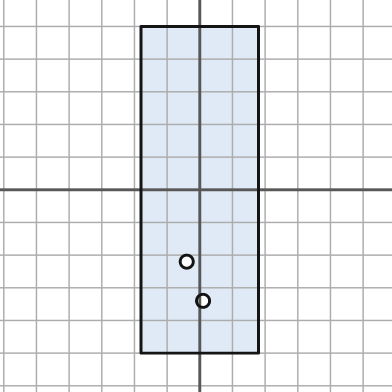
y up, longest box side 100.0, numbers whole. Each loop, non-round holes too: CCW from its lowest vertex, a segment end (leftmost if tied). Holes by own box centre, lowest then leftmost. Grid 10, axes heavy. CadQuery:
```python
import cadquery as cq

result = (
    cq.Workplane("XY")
    .moveTo(-18.0, -50.0)
    .lineTo(18.0, -50.0)
    .lineTo(18.0, 50.0)
    .lineTo(-18.0, 50.0)
    .close()
    .moveTo(1.0, -34.0)
    .circle(2.0)
    .moveTo(-4.0, -22.0)
    .circle(2.0)
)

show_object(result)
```